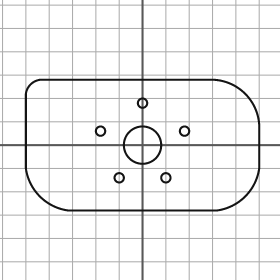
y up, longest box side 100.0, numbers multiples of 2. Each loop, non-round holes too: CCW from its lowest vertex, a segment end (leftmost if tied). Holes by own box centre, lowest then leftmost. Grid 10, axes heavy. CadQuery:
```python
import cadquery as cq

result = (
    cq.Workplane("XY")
    .moveTo(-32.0, -28.0)
    .lineTo(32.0, -28.0)
    .threePointArc((44.0, -22.0), (50.0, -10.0))
    .lineTo(50.0, 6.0)
    .threePointArc((44.0, 22.0), (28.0, 28.0))
    .lineTo(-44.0, 28.0)
    .threePointArc((-48.0, 26.0), (-50.0, 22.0))
    .lineTo(-50.0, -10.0)
    .threePointArc((-44.0, -22.0), (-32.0, -28.0))
    .close()
    .moveTo(-10.0, -14.0)
    .circle(2.0)
    .moveTo(10.0, -14.0)
    .circle(2.0)
    .moveTo(0.0, 0.0)
    .circle(8.0)
    .moveTo(-18.0, 6.0)
    .circle(2.0)
    .moveTo(18.0, 6.0)
    .circle(2.0)
    .moveTo(0.0, 18.0)
    .circle(2.0)
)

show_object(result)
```